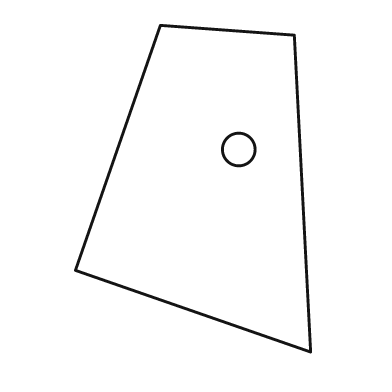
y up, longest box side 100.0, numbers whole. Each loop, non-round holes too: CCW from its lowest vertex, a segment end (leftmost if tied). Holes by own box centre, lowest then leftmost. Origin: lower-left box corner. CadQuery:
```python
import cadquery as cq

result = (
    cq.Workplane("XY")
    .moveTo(72.0, 0.0)
    .lineTo(67.0, 97.0)
    .lineTo(26.0, 100.0)
    .lineTo(0.0, 25.0)
    .close()
    .moveTo(50.0, 62.0)
    .circle(5.0)
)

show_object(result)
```